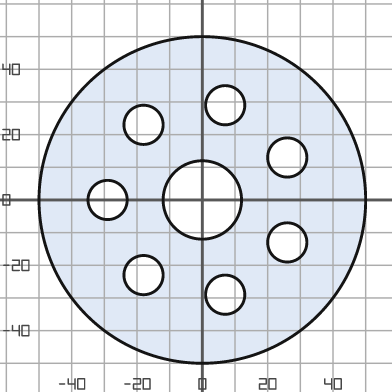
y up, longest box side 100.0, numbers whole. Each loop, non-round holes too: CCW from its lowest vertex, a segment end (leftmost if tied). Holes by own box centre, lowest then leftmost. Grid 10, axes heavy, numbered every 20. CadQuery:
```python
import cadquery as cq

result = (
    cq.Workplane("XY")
    .moveTo(0.0, 0.0)
    .circle(50.0)
    .moveTo(7.0, -29.0)
    .circle(6.0)
    .moveTo(-18.0, -23.0)
    .circle(6.0)
    .moveTo(26.0, -13.0)
    .circle(6.0)
    .moveTo(-29.0, 0.0)
    .circle(6.0)
    .moveTo(0.0, 0.0)
    .circle(12.0)
    .moveTo(26.0, 13.0)
    .circle(6.0)
    .moveTo(-18.0, 23.0)
    .circle(6.0)
    .moveTo(7.0, 29.0)
    .circle(6.0)
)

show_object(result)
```